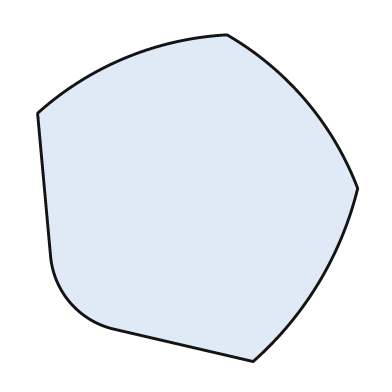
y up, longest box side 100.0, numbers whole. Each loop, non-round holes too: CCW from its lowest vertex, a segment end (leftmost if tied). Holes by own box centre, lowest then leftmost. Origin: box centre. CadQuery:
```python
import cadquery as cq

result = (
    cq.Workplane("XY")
    .moveTo(17.0, -50.0)
    .threePointArc((37.0, -26.0), (49.0, 3.0))
    .threePointArc((33.0, 30.0), (9.0, 50.0))
    .threePointArc((-22.0, 43.0), (-49.0, 26.0))
    .lineTo(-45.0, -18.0)
    .threePointArc((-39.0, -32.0), (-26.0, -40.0))
    .close()
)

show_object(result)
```